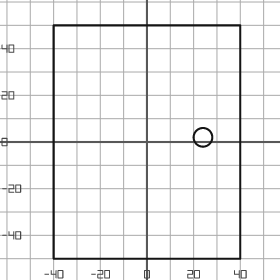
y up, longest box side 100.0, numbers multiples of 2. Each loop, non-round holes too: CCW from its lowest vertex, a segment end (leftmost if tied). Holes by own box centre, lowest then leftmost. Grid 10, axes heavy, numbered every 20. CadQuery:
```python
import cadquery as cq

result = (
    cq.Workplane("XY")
    .moveTo(-40.0, -50.0)
    .lineTo(40.0, -50.0)
    .lineTo(40.0, 50.0)
    .lineTo(-40.0, 50.0)
    .close()
    .moveTo(24.0, 2.0)
    .circle(4.0)
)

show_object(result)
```